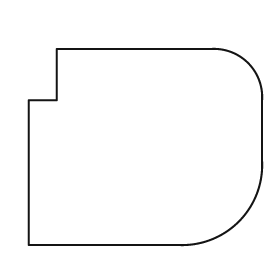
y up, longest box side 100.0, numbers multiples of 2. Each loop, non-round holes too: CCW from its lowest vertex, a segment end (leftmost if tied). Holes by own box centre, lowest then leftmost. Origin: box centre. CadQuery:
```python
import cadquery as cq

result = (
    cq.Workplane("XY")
    .moveTo(-50.0, -42.0)
    .lineTo(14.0, -42.0)
    .threePointArc((40.0, -32.0), (50.0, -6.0))
    .lineTo(50.0, 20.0)
    .threePointArc((44.0, 36.0), (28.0, 42.0))
    .lineTo(-38.0, 42.0)
    .lineTo(-38.0, 20.0)
    .lineTo(-50.0, 20.0)
    .close()
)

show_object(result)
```